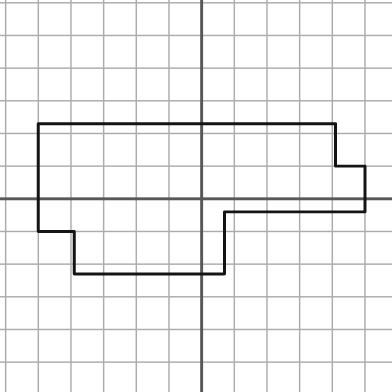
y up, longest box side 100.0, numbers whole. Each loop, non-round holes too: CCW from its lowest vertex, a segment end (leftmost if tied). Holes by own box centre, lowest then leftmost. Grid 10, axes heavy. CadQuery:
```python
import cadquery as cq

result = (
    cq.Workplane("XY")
    .moveTo(-39.0, -23.0)
    .lineTo(7.0, -23.0)
    .lineTo(7.0, -4.0)
    .lineTo(50.0, -4.0)
    .lineTo(50.0, 10.0)
    .lineTo(41.0, 10.0)
    .lineTo(41.0, 23.0)
    .lineTo(-50.0, 23.0)
    .lineTo(-50.0, -10.0)
    .lineTo(-39.0, -10.0)
    .close()
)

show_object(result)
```